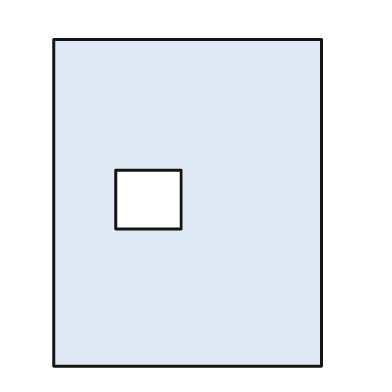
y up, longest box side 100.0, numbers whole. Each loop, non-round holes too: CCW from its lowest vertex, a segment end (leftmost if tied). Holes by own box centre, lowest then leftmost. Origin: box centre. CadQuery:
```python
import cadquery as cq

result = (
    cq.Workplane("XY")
    .moveTo(-41.0, -50.0)
    .lineTo(41.0, -50.0)
    .lineTo(41.0, 50.0)
    .lineTo(-41.0, 50.0)
    .close()
    .moveTo(-22.0, -8.0)
    .lineTo(-2.0, -8.0)
    .lineTo(-2.0, 10.0)
    .lineTo(-22.0, 10.0)
    .close()
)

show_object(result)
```